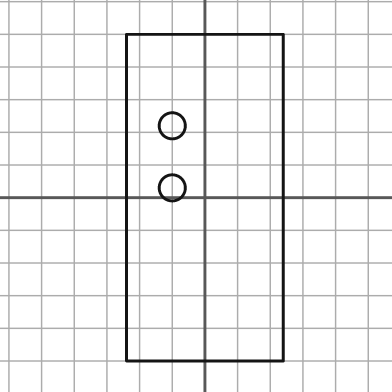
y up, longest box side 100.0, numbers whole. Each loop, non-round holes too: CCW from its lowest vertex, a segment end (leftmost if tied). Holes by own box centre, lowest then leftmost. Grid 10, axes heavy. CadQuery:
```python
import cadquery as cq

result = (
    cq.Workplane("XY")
    .moveTo(-24.0, -50.0)
    .lineTo(24.0, -50.0)
    .lineTo(24.0, 50.0)
    .lineTo(-24.0, 50.0)
    .close()
    .moveTo(-10.0, 3.0)
    .circle(4.0)
    .moveTo(-10.0, 22.0)
    .circle(4.0)
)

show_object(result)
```